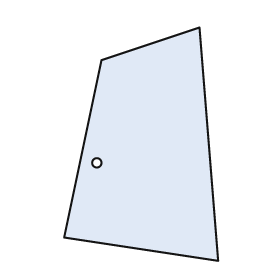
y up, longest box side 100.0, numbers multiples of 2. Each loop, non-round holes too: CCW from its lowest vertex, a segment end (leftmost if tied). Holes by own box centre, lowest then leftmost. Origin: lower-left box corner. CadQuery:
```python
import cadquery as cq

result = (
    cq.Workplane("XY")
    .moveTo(66.0, 0.0)
    .lineTo(58.0, 100.0)
    .lineTo(16.0, 86.0)
    .lineTo(0.0, 10.0)
    .close()
    .moveTo(14.0, 42.0)
    .circle(2.0)
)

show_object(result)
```